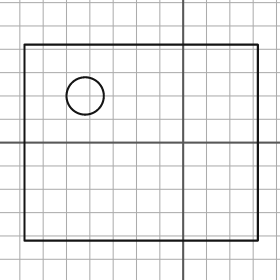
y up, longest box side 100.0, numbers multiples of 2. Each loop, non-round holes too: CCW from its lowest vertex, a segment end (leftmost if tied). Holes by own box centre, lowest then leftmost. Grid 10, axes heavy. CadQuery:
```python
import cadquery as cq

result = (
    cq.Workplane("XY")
    .moveTo(-68.0, -42.0)
    .lineTo(32.0, -42.0)
    .lineTo(32.0, 42.0)
    .lineTo(-68.0, 42.0)
    .close()
    .moveTo(-42.0, 20.0)
    .circle(8.0)
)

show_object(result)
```